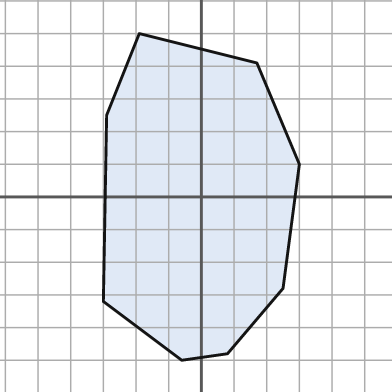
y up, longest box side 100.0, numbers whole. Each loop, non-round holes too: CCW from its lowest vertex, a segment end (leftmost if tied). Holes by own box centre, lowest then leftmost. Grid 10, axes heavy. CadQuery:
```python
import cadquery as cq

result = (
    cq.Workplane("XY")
    .moveTo(-6.0, -50.0)
    .lineTo(8.0, -48.0)
    .lineTo(25.0, -28.0)
    .lineTo(30.0, 10.0)
    .lineTo(17.0, 41.0)
    .lineTo(-19.0, 50.0)
    .lineTo(-29.0, 25.0)
    .lineTo(-30.0, -32.0)
    .close()
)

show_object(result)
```